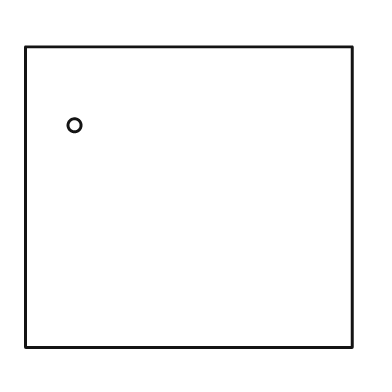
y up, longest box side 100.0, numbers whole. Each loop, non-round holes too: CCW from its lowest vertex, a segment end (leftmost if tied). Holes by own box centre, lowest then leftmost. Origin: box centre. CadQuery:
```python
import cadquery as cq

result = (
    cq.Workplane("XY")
    .moveTo(-50.0, -46.0)
    .lineTo(50.0, -46.0)
    .lineTo(50.0, 46.0)
    .lineTo(-50.0, 46.0)
    .close()
    .moveTo(-35.0, 22.0)
    .circle(2.0)
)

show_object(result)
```